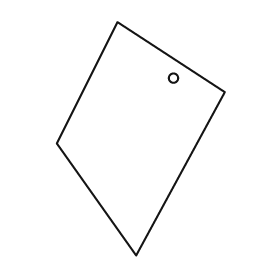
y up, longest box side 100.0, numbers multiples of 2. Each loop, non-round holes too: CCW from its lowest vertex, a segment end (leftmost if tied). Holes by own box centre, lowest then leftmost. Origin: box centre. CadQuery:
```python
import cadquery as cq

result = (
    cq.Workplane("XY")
    .moveTo(-2.0, -50.0)
    .lineTo(36.0, 20.0)
    .lineTo(-10.0, 50.0)
    .lineTo(-36.0, -2.0)
    .close()
    .moveTo(14.0, 26.0)
    .circle(2.0)
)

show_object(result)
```